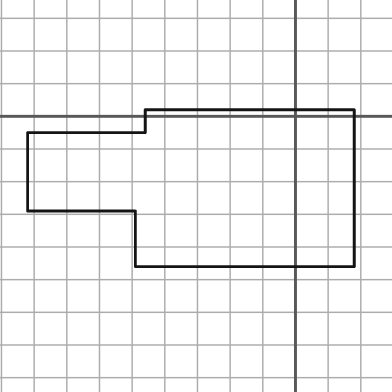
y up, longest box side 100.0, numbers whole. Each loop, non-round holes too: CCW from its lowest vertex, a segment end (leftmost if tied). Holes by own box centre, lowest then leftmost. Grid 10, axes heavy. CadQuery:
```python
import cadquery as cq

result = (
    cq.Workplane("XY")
    .moveTo(-49.0, -46.0)
    .lineTo(18.0, -46.0)
    .lineTo(18.0, 2.0)
    .lineTo(-46.0, 2.0)
    .lineTo(-46.0, -5.0)
    .lineTo(-82.0, -5.0)
    .lineTo(-82.0, -29.0)
    .lineTo(-49.0, -29.0)
    .close()
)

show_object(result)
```